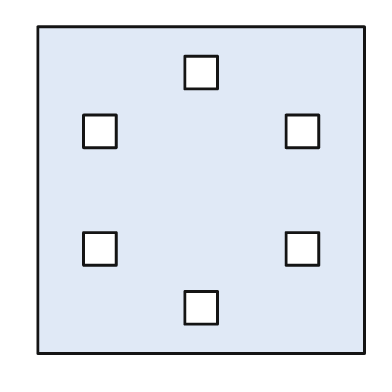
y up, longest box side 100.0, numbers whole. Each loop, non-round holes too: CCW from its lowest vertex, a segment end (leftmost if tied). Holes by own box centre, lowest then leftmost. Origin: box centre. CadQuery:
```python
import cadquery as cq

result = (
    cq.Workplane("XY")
    .moveTo(-50.0, -50.0)
    .lineTo(50.0, -50.0)
    .lineTo(50.0, 50.0)
    .lineTo(-50.0, 50.0)
    .close()
    .moveTo(-5.0, -41.0)
    .lineTo(5.0, -41.0)
    .lineTo(5.0, -31.0)
    .lineTo(-5.0, -31.0)
    .close()
    .moveTo(-36.0, -23.0)
    .lineTo(-26.0, -23.0)
    .lineTo(-26.0, -13.0)
    .lineTo(-36.0, -13.0)
    .close()
    .moveTo(26.0, -23.0)
    .lineTo(36.0, -23.0)
    .lineTo(36.0, -13.0)
    .lineTo(26.0, -13.0)
    .close()
    .moveTo(-36.0, 13.0)
    .lineTo(-26.0, 13.0)
    .lineTo(-26.0, 23.0)
    .lineTo(-36.0, 23.0)
    .close()
    .moveTo(26.0, 13.0)
    .lineTo(36.0, 13.0)
    .lineTo(36.0, 23.0)
    .lineTo(26.0, 23.0)
    .close()
    .moveTo(-5.0, 31.0)
    .lineTo(5.0, 31.0)
    .lineTo(5.0, 41.0)
    .lineTo(-5.0, 41.0)
    .close()
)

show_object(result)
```